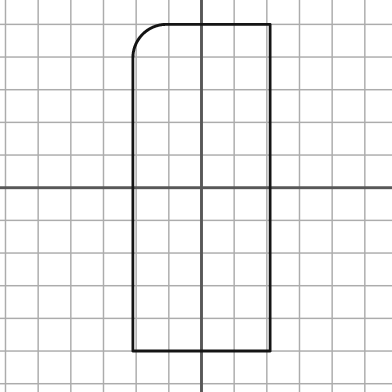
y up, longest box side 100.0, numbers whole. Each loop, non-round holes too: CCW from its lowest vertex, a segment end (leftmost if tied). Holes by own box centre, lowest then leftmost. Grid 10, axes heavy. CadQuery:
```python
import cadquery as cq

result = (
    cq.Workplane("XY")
    .moveTo(-21.0, -50.0)
    .lineTo(21.0, -50.0)
    .lineTo(21.0, 50.0)
    .lineTo(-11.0, 50.0)
    .threePointArc((-18.0, 47.0), (-21.0, 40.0))
    .close()
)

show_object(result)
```